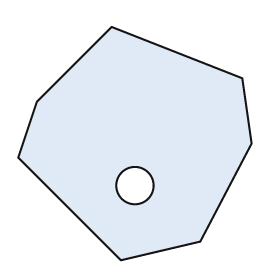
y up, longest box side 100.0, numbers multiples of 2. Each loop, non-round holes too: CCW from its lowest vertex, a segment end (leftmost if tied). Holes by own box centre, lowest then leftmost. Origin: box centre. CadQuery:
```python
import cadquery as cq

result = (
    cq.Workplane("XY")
    .moveTo(-6.0, -50.0)
    .lineTo(28.0, -42.0)
    .lineTo(50.0, 0.0)
    .lineTo(46.0, 28.0)
    .lineTo(-10.0, 50.0)
    .lineTo(-42.0, 18.0)
    .lineTo(-50.0, -6.0)
    .close()
    .moveTo(0.0, -18.0)
    .circle(8.0)
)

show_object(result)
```